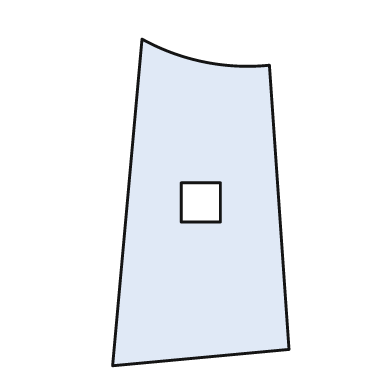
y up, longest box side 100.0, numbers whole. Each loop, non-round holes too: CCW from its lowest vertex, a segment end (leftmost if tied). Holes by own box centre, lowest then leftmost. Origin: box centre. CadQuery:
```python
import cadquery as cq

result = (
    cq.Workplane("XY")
    .moveTo(-27.0, -50.0)
    .lineTo(27.0, -45.0)
    .lineTo(21.0, 42.0)
    .threePointArc((1.0, 43.0), (-18.0, 50.0))
    .close()
    .moveTo(-6.0, -6.0)
    .lineTo(6.0, -6.0)
    .lineTo(6.0, 6.0)
    .lineTo(-6.0, 6.0)
    .close()
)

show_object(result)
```